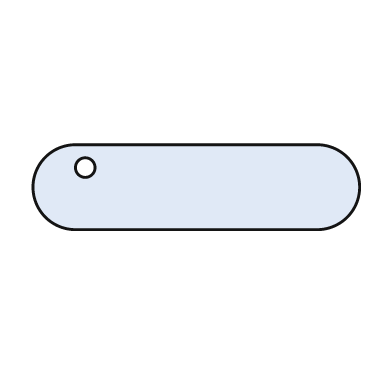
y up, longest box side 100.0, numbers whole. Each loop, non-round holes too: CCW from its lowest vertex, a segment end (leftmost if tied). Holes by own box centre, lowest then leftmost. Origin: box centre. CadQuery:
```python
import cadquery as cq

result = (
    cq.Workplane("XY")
    .moveTo(-37.0, -13.0)
    .lineTo(37.0, -13.0)
    .threePointArc((50.0, 0.0), (37.0, 13.0))
    .lineTo(-37.0, 13.0)
    .threePointArc((-50.0, 0.0), (-37.0, -13.0))
    .close()
    .moveTo(-34.0, 6.0)
    .circle(3.0)
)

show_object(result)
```